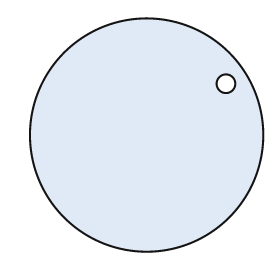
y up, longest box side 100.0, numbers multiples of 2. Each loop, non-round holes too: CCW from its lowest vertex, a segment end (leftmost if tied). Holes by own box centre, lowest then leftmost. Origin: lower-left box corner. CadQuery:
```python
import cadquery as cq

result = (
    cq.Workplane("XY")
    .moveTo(50.0, 50.0)
    .circle(50.0)
    .moveTo(84.0, 72.0)
    .circle(4.0)
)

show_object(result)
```